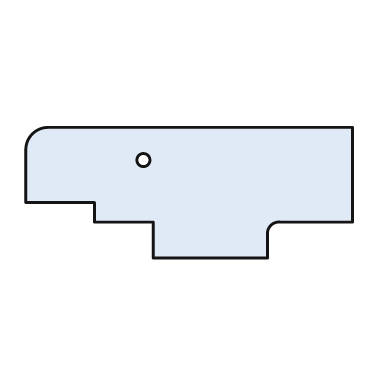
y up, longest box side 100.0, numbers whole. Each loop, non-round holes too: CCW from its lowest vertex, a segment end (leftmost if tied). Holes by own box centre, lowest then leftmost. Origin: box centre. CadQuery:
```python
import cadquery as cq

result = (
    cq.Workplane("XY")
    .moveTo(-11.0, -20.0)
    .lineTo(24.0, -20.0)
    .lineTo(24.0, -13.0)
    .threePointArc((25.0, -10.0), (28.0, -9.0))
    .lineTo(50.0, -9.0)
    .lineTo(50.0, 20.0)
    .lineTo(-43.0, 20.0)
    .threePointArc((-48.0, 18.0), (-50.0, 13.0))
    .lineTo(-50.0, -3.0)
    .lineTo(-29.0, -3.0)
    .lineTo(-29.0, -9.0)
    .lineTo(-11.0, -9.0)
    .close()
    .moveTo(-14.0, 10.0)
    .circle(2.0)
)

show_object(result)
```